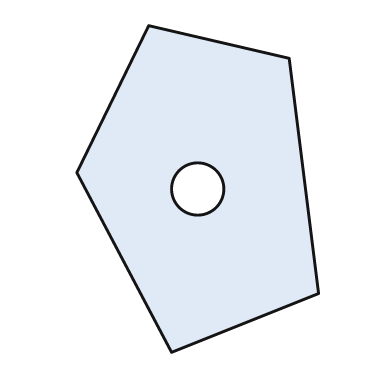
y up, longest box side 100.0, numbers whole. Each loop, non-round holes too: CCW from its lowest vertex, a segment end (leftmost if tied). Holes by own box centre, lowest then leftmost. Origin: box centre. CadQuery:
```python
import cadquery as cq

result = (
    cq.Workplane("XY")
    .moveTo(-8.0, -50.0)
    .lineTo(37.0, -32.0)
    .lineTo(28.0, 40.0)
    .lineTo(-15.0, 50.0)
    .lineTo(-37.0, 5.0)
    .close()
    .moveTo(0.0, 0.0)
    .circle(8.0)
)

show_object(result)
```